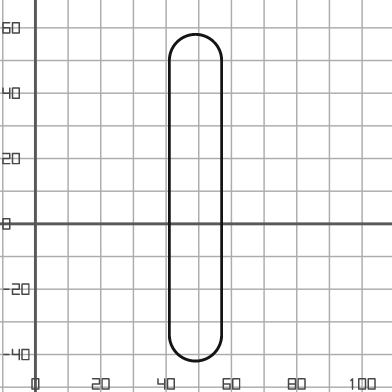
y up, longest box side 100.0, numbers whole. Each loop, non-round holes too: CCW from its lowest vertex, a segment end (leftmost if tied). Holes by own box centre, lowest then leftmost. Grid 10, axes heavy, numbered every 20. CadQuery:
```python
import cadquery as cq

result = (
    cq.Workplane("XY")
    .moveTo(41.0, -34.0)
    .threePointArc((49.0, -42.0), (57.0, -34.0))
    .lineTo(57.0, 50.0)
    .threePointArc((49.0, 58.0), (41.0, 50.0))
    .close()
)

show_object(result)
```